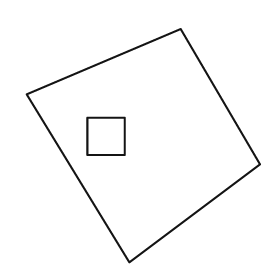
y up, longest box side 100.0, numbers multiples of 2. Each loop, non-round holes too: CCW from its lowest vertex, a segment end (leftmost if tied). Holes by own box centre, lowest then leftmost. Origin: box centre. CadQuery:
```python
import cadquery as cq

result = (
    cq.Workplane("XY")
    .moveTo(-6.0, -50.0)
    .lineTo(50.0, -8.0)
    .lineTo(16.0, 50.0)
    .lineTo(-50.0, 22.0)
    .close()
    .moveTo(-24.0, -4.0)
    .lineTo(-8.0, -4.0)
    .lineTo(-8.0, 12.0)
    .lineTo(-24.0, 12.0)
    .close()
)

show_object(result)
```